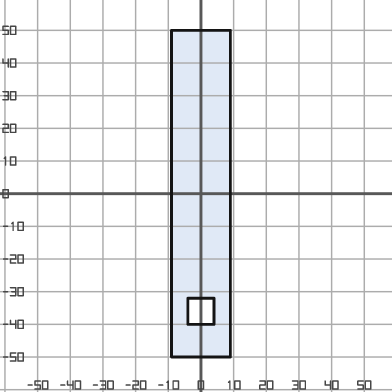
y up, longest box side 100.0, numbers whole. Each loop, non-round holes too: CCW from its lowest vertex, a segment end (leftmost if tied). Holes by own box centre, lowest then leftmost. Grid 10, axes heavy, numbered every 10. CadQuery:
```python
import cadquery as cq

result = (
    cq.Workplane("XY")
    .moveTo(-9.0, -50.0)
    .lineTo(9.0, -50.0)
    .lineTo(9.0, 50.0)
    .lineTo(-9.0, 50.0)
    .close()
    .moveTo(-4.0, -40.0)
    .lineTo(4.0, -40.0)
    .lineTo(4.0, -32.0)
    .lineTo(-4.0, -32.0)
    .close()
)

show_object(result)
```